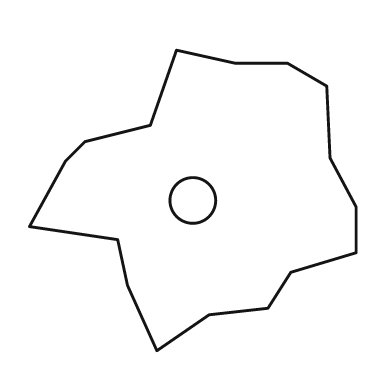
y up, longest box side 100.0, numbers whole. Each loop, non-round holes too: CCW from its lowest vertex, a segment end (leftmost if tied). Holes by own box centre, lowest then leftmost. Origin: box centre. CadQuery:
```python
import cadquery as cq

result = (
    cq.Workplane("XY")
    .moveTo(-11.0, -46.0)
    .lineTo(5.0, -35.0)
    .lineTo(23.0, -33.0)
    .lineTo(30.0, -22.0)
    .lineTo(50.0, -16.0)
    .lineTo(50.0, -2.0)
    .lineTo(42.0, 13.0)
    .lineTo(41.0, 35.0)
    .lineTo(29.0, 42.0)
    .lineTo(13.0, 42.0)
    .lineTo(-5.0, 46.0)
    .lineTo(-13.0, 23.0)
    .lineTo(-33.0, 18.0)
    .lineTo(-39.0, 12.0)
    .lineTo(-50.0, -8.0)
    .lineTo(-23.0, -12.0)
    .lineTo(-20.0, -26.0)
    .close()
    .moveTo(0.0, 0.0)
    .circle(7.0)
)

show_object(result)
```